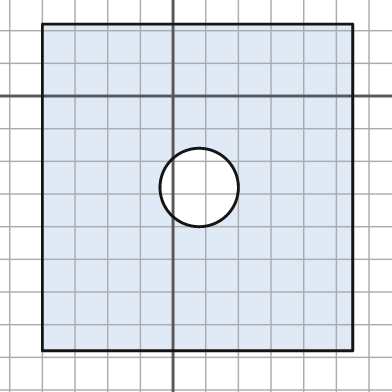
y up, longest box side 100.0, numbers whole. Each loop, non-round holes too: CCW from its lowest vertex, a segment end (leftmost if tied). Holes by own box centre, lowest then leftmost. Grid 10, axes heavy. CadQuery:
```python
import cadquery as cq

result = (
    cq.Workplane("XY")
    .moveTo(-40.0, -78.0)
    .lineTo(55.0, -78.0)
    .lineTo(55.0, 22.0)
    .lineTo(-40.0, 22.0)
    .close()
    .moveTo(8.0, -28.0)
    .circle(12.0)
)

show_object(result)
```